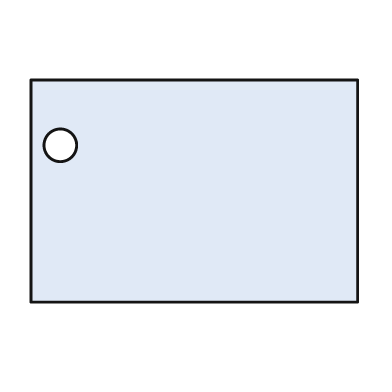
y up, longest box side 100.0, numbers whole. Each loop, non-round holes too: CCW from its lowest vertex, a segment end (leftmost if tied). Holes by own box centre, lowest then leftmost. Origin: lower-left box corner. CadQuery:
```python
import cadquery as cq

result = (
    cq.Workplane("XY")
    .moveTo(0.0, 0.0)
    .lineTo(100.0, 0.0)
    .lineTo(100.0, 68.0)
    .lineTo(0.0, 68.0)
    .close()
    .moveTo(9.0, 48.0)
    .circle(5.0)
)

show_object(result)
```